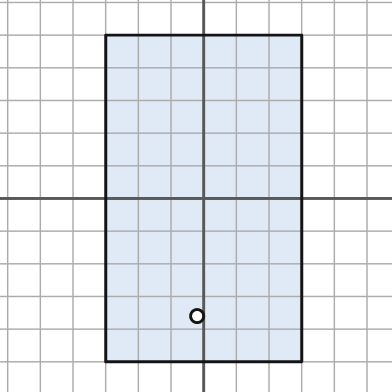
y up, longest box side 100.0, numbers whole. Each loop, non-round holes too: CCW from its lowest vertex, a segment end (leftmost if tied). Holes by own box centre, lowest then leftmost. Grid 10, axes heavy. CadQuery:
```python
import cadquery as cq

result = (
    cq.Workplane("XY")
    .moveTo(-30.0, -50.0)
    .lineTo(30.0, -50.0)
    .lineTo(30.0, 50.0)
    .lineTo(-30.0, 50.0)
    .close()
    .moveTo(-2.0, -36.0)
    .circle(2.0)
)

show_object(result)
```